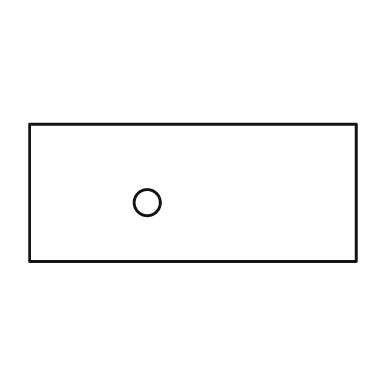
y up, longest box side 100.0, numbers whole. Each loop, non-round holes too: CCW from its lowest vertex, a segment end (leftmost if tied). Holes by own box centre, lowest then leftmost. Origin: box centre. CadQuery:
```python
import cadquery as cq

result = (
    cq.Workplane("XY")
    .moveTo(-50.0, -21.0)
    .lineTo(50.0, -21.0)
    .lineTo(50.0, 21.0)
    .lineTo(-50.0, 21.0)
    .close()
    .moveTo(-14.0, -3.0)
    .circle(4.0)
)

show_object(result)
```